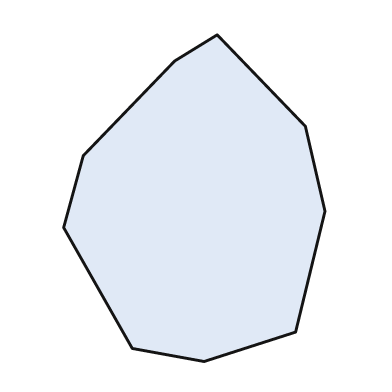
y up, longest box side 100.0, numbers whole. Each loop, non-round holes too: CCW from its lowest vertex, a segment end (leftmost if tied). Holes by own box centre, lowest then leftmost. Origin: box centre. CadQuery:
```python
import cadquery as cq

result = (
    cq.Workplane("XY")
    .moveTo(3.0, -50.0)
    .lineTo(31.0, -41.0)
    .lineTo(40.0, -4.0)
    .lineTo(34.0, 22.0)
    .lineTo(7.0, 50.0)
    .lineTo(-6.0, 42.0)
    .lineTo(-34.0, 13.0)
    .lineTo(-40.0, -9.0)
    .lineTo(-19.0, -46.0)
    .close()
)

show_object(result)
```